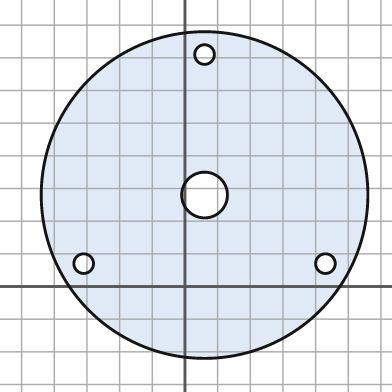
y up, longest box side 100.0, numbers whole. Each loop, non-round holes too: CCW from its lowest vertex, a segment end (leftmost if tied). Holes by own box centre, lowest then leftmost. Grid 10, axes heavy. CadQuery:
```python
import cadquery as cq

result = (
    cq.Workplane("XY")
    .moveTo(6.0, 28.0)
    .circle(50.0)
    .moveTo(-31.0, 7.0)
    .circle(3.0)
    .moveTo(43.0, 7.0)
    .circle(3.0)
    .moveTo(6.0, 28.0)
    .circle(7.0)
    .moveTo(6.0, 71.0)
    .circle(3.0)
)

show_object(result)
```